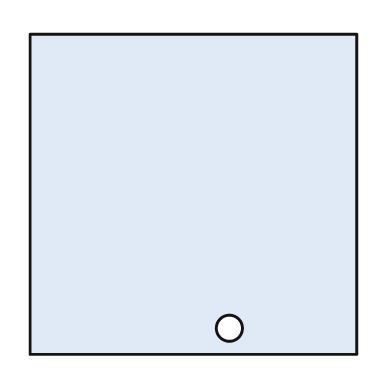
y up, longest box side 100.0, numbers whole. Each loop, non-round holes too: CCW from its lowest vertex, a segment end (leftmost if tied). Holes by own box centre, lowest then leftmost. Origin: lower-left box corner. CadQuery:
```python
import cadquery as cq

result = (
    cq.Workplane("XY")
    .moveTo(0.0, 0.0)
    .lineTo(100.0, 0.0)
    .lineTo(100.0, 98.0)
    .lineTo(0.0, 98.0)
    .close()
    .moveTo(61.0, 8.0)
    .circle(4.0)
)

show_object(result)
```